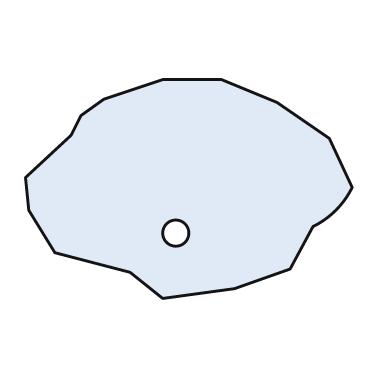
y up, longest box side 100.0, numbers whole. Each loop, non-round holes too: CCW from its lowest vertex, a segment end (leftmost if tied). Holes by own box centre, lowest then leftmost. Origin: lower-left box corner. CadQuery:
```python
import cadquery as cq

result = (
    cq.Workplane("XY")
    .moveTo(42.0, 0.0)
    .lineTo(64.0, 3.0)
    .lineTo(81.0, 9.0)
    .lineTo(88.0, 22.0)
    .threePointArc((95.0, 27.0), (100.0, 34.0))
    .lineTo(93.0, 49.0)
    .lineTo(77.0, 60.0)
    .lineTo(60.0, 67.0)
    .lineTo(42.0, 67.0)
    .lineTo(24.0, 61.0)
    .lineTo(17.0, 56.0)
    .lineTo(14.0, 50.0)
    .lineTo(0.0, 37.0)
    .lineTo(1.0, 27.0)
    .lineTo(9.0, 14.0)
    .lineTo(32.0, 8.0)
    .close()
    .moveTo(46.0, 20.0)
    .circle(4.0)
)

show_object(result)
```